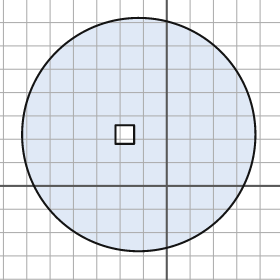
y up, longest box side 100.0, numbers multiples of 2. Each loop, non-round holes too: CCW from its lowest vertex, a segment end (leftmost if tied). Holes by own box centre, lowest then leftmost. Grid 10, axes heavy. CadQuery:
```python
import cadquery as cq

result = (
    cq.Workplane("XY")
    .moveTo(-12.0, 22.0)
    .circle(50.0)
    .moveTo(-22.0, 18.0)
    .lineTo(-14.0, 18.0)
    .lineTo(-14.0, 26.0)
    .lineTo(-22.0, 26.0)
    .close()
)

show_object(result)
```